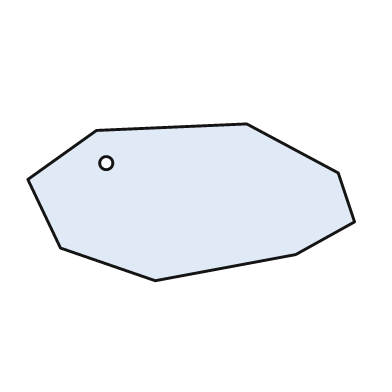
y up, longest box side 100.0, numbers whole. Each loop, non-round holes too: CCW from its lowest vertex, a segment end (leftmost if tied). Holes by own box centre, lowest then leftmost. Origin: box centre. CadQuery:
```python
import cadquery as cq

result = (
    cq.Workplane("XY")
    .moveTo(-11.0, -24.0)
    .lineTo(32.0, -16.0)
    .lineTo(50.0, -6.0)
    .lineTo(45.0, 9.0)
    .lineTo(17.0, 24.0)
    .lineTo(-29.0, 22.0)
    .lineTo(-50.0, 7.0)
    .lineTo(-40.0, -14.0)
    .close()
    .moveTo(-26.0, 12.0)
    .circle(2.0)
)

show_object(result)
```